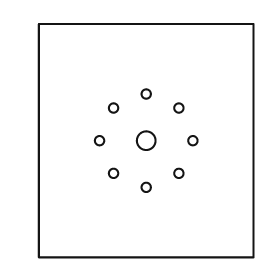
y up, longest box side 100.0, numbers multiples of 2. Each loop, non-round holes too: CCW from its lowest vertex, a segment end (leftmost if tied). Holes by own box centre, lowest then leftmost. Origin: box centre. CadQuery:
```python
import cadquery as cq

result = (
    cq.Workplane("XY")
    .moveTo(-46.0, -50.0)
    .lineTo(46.0, -50.0)
    .lineTo(46.0, 50.0)
    .lineTo(-46.0, 50.0)
    .close()
    .moveTo(0.0, -20.0)
    .circle(2.0)
    .moveTo(-14.0, -14.0)
    .circle(2.0)
    .moveTo(14.0, -14.0)
    .circle(2.0)
    .moveTo(-20.0, 0.0)
    .circle(2.0)
    .moveTo(0.0, 0.0)
    .circle(4.0)
    .moveTo(20.0, 0.0)
    .circle(2.0)
    .moveTo(-14.0, 14.0)
    .circle(2.0)
    .moveTo(14.0, 14.0)
    .circle(2.0)
    .moveTo(0.0, 20.0)
    .circle(2.0)
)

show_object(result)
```